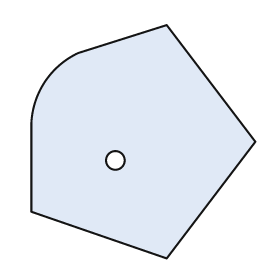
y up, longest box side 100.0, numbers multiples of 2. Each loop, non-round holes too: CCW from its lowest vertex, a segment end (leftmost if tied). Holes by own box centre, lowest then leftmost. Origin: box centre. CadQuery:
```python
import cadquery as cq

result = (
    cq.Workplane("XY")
    .moveTo(10.0, -50.0)
    .lineTo(48.0, 0.0)
    .lineTo(10.0, 50.0)
    .lineTo(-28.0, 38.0)
    .threePointArc((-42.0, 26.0), (-48.0, 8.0))
    .lineTo(-48.0, -30.0)
    .close()
    .moveTo(-12.0, -8.0)
    .circle(4.0)
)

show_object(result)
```